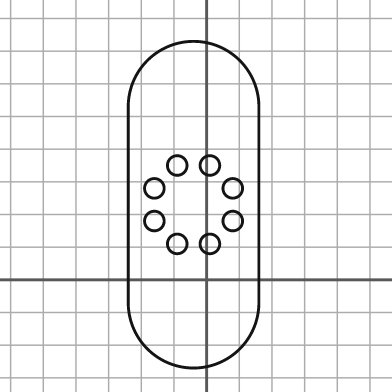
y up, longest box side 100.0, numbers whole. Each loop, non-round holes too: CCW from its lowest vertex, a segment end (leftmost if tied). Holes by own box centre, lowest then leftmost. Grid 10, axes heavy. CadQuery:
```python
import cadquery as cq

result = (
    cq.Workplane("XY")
    .moveTo(-24.0, -7.0)
    .threePointArc((-4.0, -27.0), (16.0, -7.0))
    .lineTo(16.0, 53.0)
    .threePointArc((-4.0, 73.0), (-24.0, 53.0))
    .close()
    .moveTo(-9.0, 11.0)
    .circle(3.0)
    .moveTo(1.0, 11.0)
    .circle(3.0)
    .moveTo(-16.0, 18.0)
    .circle(3.0)
    .moveTo(8.0, 18.0)
    .circle(3.0)
    .moveTo(-16.0, 28.0)
    .circle(3.0)
    .moveTo(8.0, 28.0)
    .circle(3.0)
    .moveTo(-9.0, 35.0)
    .circle(3.0)
    .moveTo(1.0, 35.0)
    .circle(3.0)
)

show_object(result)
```